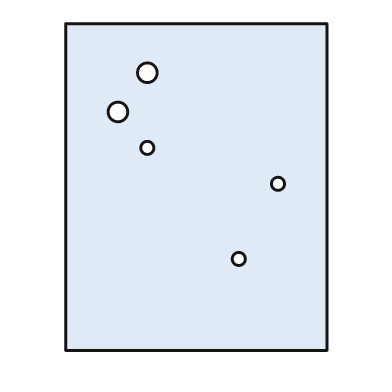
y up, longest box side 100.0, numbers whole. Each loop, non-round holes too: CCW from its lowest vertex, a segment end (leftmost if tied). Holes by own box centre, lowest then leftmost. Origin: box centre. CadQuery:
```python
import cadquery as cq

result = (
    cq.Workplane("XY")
    .moveTo(-40.0, -50.0)
    .lineTo(40.0, -50.0)
    .lineTo(40.0, 50.0)
    .lineTo(-40.0, 50.0)
    .close()
    .moveTo(13.0, -22.0)
    .circle(2.0)
    .moveTo(25.0, 1.0)
    .circle(2.0)
    .moveTo(-15.0, 12.0)
    .circle(2.0)
    .moveTo(-24.0, 23.0)
    .circle(3.0)
    .moveTo(-15.0, 35.0)
    .circle(3.0)
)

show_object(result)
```